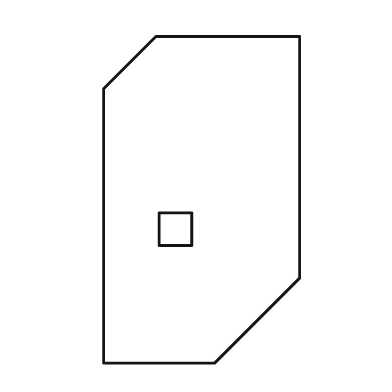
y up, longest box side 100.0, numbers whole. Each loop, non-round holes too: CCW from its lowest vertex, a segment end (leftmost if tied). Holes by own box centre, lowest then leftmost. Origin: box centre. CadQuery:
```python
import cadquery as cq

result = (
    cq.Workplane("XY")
    .moveTo(-30.0, -50.0)
    .lineTo(4.0, -50.0)
    .lineTo(30.0, -24.0)
    .lineTo(30.0, 50.0)
    .lineTo(-14.0, 50.0)
    .lineTo(-30.0, 34.0)
    .close()
    .moveTo(-13.0, -14.0)
    .lineTo(-3.0, -14.0)
    .lineTo(-3.0, -4.0)
    .lineTo(-13.0, -4.0)
    .close()
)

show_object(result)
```